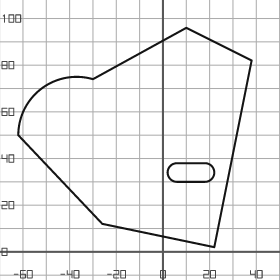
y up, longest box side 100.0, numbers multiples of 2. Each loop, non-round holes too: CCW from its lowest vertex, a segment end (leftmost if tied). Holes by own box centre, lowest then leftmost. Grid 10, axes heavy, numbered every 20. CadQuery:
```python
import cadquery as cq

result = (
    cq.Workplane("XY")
    .moveTo(22.0, 2.0)
    .lineTo(38.0, 82.0)
    .lineTo(10.0, 96.0)
    .lineTo(-30.0, 74.0)
    .threePointArc((-52.0, 70.0), (-62.0, 50.0))
    .lineTo(-26.0, 12.0)
    .close()
    .moveTo(6.0, 30.0)
    .lineTo(18.0, 30.0)
    .threePointArc((22.0, 34.0), (18.0, 38.0))
    .lineTo(6.0, 38.0)
    .threePointArc((2.0, 34.0), (6.0, 30.0))
    .close()
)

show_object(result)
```